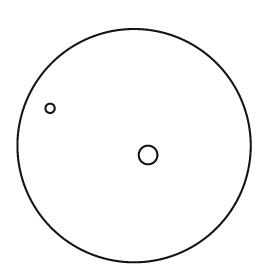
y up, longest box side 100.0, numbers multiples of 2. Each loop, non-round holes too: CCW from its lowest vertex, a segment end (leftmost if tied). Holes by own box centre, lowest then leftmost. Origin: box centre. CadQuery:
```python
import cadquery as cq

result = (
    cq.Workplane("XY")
    .moveTo(0.0, 0.0)
    .circle(50.0)
    .moveTo(6.0, -4.0)
    .circle(4.0)
    .moveTo(-36.0, 16.0)
    .circle(2.0)
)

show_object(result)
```